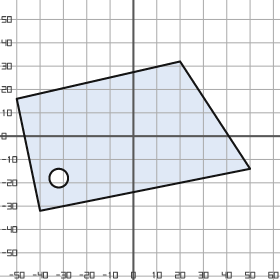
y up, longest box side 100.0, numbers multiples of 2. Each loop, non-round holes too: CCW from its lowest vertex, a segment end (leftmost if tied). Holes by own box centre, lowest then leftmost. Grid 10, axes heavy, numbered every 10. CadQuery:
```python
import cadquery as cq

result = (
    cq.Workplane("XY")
    .moveTo(-40.0, -32.0)
    .lineTo(50.0, -14.0)
    .lineTo(20.0, 32.0)
    .lineTo(-50.0, 16.0)
    .close()
    .moveTo(-32.0, -18.0)
    .circle(4.0)
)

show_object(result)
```